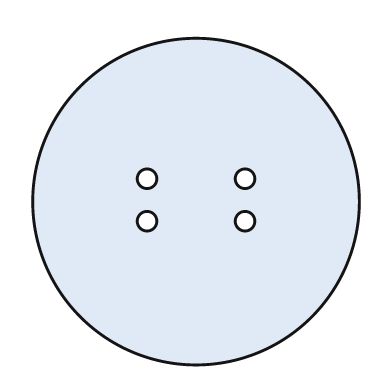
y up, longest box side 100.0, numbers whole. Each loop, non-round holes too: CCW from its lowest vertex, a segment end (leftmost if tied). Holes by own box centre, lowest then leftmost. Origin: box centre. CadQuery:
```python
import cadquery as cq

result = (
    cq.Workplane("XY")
    .moveTo(0.0, 0.0)
    .circle(50.0)
    .moveTo(-15.0, -6.0)
    .circle(3.0)
    .moveTo(15.0, -6.0)
    .circle(3.0)
    .moveTo(-15.0, 7.0)
    .circle(3.0)
    .moveTo(15.0, 7.0)
    .circle(3.0)
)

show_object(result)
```